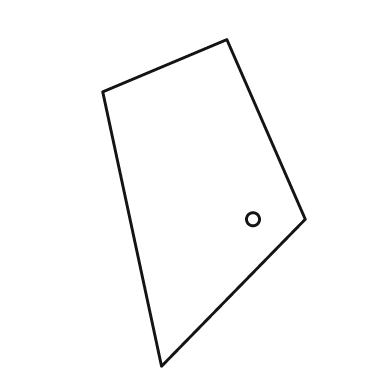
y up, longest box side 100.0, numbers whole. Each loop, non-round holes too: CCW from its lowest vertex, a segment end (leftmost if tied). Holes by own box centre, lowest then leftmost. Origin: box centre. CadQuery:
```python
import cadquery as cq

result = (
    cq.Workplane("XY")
    .moveTo(-13.0, -50.0)
    .lineTo(31.0, -5.0)
    .lineTo(7.0, 50.0)
    .lineTo(-31.0, 34.0)
    .close()
    .moveTo(15.0, -5.0)
    .circle(2.0)
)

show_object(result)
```